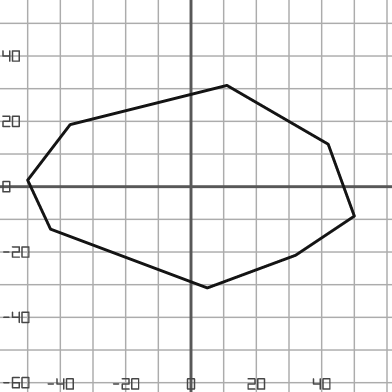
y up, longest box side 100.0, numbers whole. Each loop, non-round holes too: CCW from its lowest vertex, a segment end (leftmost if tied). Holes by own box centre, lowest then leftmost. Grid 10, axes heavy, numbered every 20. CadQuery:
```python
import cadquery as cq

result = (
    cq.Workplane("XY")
    .moveTo(5.0, -31.0)
    .lineTo(32.0, -21.0)
    .lineTo(50.0, -9.0)
    .lineTo(42.0, 13.0)
    .lineTo(11.0, 31.0)
    .lineTo(-37.0, 19.0)
    .lineTo(-50.0, 2.0)
    .lineTo(-43.0, -13.0)
    .close()
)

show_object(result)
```